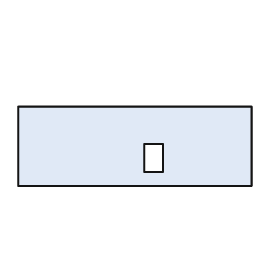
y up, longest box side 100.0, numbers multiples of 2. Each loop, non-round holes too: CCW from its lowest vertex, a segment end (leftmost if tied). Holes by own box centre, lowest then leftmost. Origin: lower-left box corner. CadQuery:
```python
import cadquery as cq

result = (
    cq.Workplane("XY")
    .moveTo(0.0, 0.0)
    .lineTo(100.0, 0.0)
    .lineTo(100.0, 34.0)
    .lineTo(0.0, 34.0)
    .close()
    .moveTo(54.0, 6.0)
    .lineTo(62.0, 6.0)
    .lineTo(62.0, 18.0)
    .lineTo(54.0, 18.0)
    .close()
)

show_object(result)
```